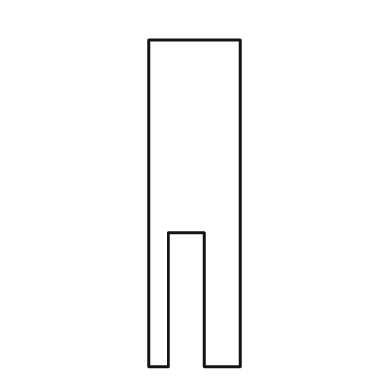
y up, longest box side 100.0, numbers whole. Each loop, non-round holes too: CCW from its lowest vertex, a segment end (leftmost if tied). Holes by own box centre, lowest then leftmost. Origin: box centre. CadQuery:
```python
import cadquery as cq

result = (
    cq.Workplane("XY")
    .moveTo(-14.0, -50.0)
    .lineTo(-8.0, -50.0)
    .lineTo(-8.0, -9.0)
    .lineTo(3.0, -9.0)
    .lineTo(3.0, -50.0)
    .lineTo(14.0, -50.0)
    .lineTo(14.0, 50.0)
    .lineTo(-14.0, 50.0)
    .close()
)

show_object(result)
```